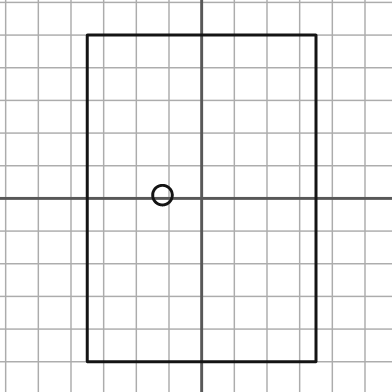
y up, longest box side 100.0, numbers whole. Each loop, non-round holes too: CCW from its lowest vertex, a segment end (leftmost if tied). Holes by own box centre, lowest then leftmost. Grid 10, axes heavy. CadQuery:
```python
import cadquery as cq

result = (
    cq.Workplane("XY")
    .moveTo(-35.0, -50.0)
    .lineTo(35.0, -50.0)
    .lineTo(35.0, 50.0)
    .lineTo(-35.0, 50.0)
    .close()
    .moveTo(-12.0, 1.0)
    .circle(3.0)
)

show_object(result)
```